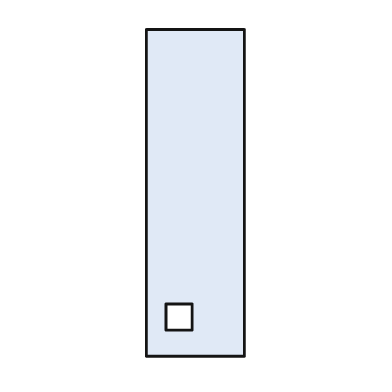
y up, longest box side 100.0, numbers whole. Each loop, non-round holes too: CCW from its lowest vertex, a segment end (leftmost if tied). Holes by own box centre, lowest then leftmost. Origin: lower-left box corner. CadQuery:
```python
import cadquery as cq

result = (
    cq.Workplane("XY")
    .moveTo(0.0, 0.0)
    .lineTo(30.0, 0.0)
    .lineTo(30.0, 100.0)
    .lineTo(0.0, 100.0)
    .close()
    .moveTo(6.0, 8.0)
    .lineTo(14.0, 8.0)
    .lineTo(14.0, 16.0)
    .lineTo(6.0, 16.0)
    .close()
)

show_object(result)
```